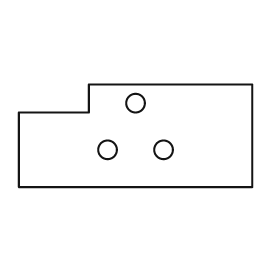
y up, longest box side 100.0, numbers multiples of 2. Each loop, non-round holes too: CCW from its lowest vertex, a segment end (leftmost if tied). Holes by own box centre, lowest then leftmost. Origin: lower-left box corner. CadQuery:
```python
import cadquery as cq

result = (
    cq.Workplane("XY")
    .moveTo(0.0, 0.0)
    .lineTo(100.0, 0.0)
    .lineTo(100.0, 44.0)
    .lineTo(30.0, 44.0)
    .lineTo(30.0, 32.0)
    .lineTo(0.0, 32.0)
    .close()
    .moveTo(38.0, 16.0)
    .circle(4.0)
    .moveTo(62.0, 16.0)
    .circle(4.0)
    .moveTo(50.0, 36.0)
    .circle(4.0)
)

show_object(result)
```